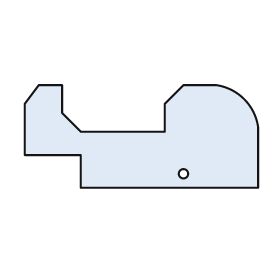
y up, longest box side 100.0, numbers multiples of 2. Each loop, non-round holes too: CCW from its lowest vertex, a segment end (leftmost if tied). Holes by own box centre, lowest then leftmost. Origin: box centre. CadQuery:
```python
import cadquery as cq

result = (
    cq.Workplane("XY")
    .moveTo(-26.0, -22.0)
    .lineTo(50.0, -22.0)
    .lineTo(50.0, 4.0)
    .threePointArc((44.0, 16.0), (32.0, 22.0))
    .lineTo(18.0, 22.0)
    .lineTo(10.0, 14.0)
    .lineTo(10.0, 2.0)
    .lineTo(-26.0, 2.0)
    .lineTo(-34.0, 10.0)
    .lineTo(-34.0, 22.0)
    .lineTo(-44.0, 22.0)
    .lineTo(-50.0, 14.0)
    .lineTo(-50.0, -8.0)
    .lineTo(-26.0, -8.0)
    .close()
    .moveTo(18.0, -16.0)
    .circle(2.0)
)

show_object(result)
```